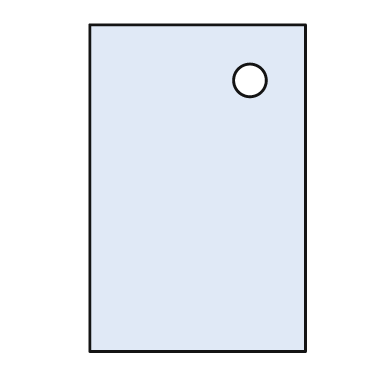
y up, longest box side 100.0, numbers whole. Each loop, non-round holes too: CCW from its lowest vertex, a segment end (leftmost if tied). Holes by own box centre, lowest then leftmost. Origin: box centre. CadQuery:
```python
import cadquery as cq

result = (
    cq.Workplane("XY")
    .moveTo(-33.0, -50.0)
    .lineTo(33.0, -50.0)
    .lineTo(33.0, 50.0)
    .lineTo(-33.0, 50.0)
    .close()
    .moveTo(16.0, 33.0)
    .circle(5.0)
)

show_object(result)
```